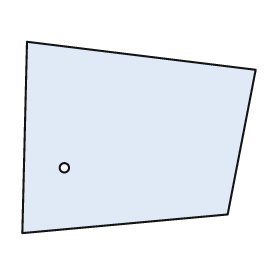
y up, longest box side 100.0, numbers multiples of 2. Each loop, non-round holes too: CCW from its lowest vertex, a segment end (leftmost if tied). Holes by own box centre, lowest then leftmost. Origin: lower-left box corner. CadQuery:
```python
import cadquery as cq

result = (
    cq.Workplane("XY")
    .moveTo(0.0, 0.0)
    .lineTo(88.0, 8.0)
    .lineTo(100.0, 70.0)
    .lineTo(2.0, 82.0)
    .close()
    .moveTo(18.0, 28.0)
    .circle(2.0)
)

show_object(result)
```